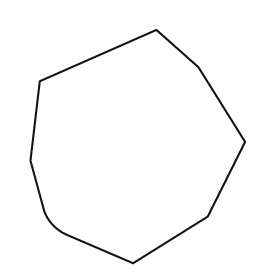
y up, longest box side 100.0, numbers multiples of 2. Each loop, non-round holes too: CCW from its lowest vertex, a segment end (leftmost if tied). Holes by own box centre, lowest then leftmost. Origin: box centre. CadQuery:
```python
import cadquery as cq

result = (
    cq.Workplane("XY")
    .moveTo(-2.0, -50.0)
    .lineTo(30.0, -30.0)
    .lineTo(46.0, 2.0)
    .lineTo(26.0, 34.0)
    .lineTo(8.0, 50.0)
    .lineTo(-42.0, 28.0)
    .lineTo(-46.0, -6.0)
    .lineTo(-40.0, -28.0)
    .threePointArc((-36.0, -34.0), (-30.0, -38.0))
    .close()
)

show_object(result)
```